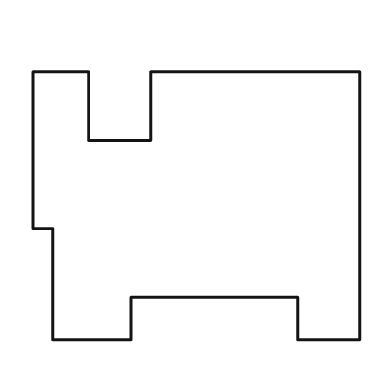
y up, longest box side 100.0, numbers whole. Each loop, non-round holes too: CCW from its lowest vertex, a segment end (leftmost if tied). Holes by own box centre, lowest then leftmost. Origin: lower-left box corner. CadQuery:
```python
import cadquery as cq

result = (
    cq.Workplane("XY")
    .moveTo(6.0, 0.0)
    .lineTo(30.0, 0.0)
    .lineTo(30.0, 13.0)
    .lineTo(81.0, 13.0)
    .lineTo(81.0, 0.0)
    .lineTo(100.0, 0.0)
    .lineTo(100.0, 82.0)
    .lineTo(36.0, 82.0)
    .lineTo(36.0, 61.0)
    .lineTo(17.0, 61.0)
    .lineTo(17.0, 82.0)
    .lineTo(0.0, 82.0)
    .lineTo(0.0, 34.0)
    .lineTo(6.0, 34.0)
    .close()
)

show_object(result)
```